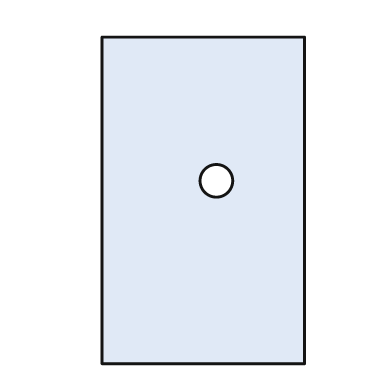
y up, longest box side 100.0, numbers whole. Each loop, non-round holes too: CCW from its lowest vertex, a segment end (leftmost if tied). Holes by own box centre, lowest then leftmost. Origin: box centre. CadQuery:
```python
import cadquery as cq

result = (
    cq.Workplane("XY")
    .moveTo(-31.0, -50.0)
    .lineTo(31.0, -50.0)
    .lineTo(31.0, 50.0)
    .lineTo(-31.0, 50.0)
    .close()
    .moveTo(4.0, 6.0)
    .circle(5.0)
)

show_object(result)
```